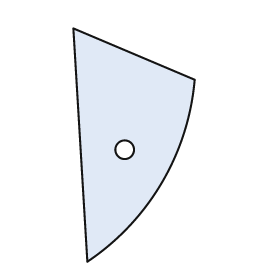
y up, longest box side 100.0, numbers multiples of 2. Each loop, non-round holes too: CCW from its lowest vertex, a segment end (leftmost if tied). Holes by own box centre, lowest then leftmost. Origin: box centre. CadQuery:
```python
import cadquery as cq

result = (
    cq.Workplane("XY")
    .moveTo(-20.0, -50.0)
    .threePointArc((12.0, -16.0), (26.0, 28.0))
    .lineTo(-26.0, 50.0)
    .close()
    .moveTo(-4.0, -2.0)
    .circle(4.0)
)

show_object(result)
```